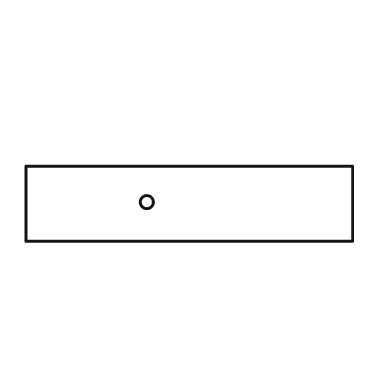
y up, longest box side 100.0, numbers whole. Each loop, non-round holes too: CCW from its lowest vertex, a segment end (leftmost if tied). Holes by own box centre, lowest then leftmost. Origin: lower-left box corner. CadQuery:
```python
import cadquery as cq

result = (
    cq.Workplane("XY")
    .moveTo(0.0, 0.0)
    .lineTo(100.0, 0.0)
    .lineTo(100.0, 23.0)
    .lineTo(0.0, 23.0)
    .close()
    .moveTo(37.0, 12.0)
    .circle(2.0)
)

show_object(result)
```